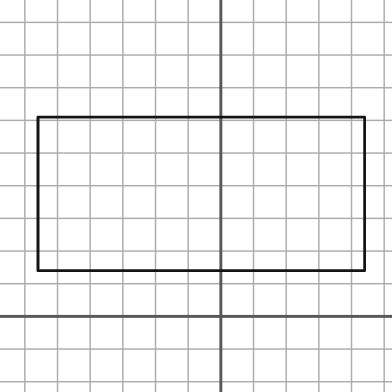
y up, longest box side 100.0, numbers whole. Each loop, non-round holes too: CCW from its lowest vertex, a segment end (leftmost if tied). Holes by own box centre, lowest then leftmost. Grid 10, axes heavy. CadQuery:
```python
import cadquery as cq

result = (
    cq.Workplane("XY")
    .moveTo(-56.0, 14.0)
    .lineTo(44.0, 14.0)
    .lineTo(44.0, 61.0)
    .lineTo(-56.0, 61.0)
    .close()
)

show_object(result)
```